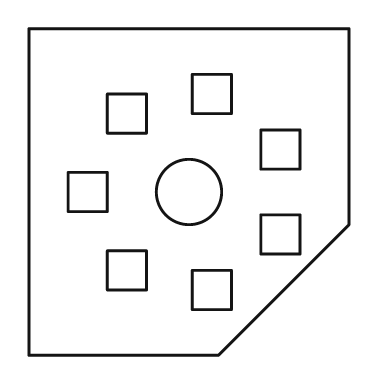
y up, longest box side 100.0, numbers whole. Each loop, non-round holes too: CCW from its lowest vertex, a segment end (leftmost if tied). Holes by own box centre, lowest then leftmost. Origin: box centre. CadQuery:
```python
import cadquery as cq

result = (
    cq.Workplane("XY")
    .moveTo(-49.0, -50.0)
    .lineTo(9.0, -50.0)
    .lineTo(49.0, -10.0)
    .lineTo(49.0, 50.0)
    .lineTo(-49.0, 50.0)
    .close()
    .moveTo(1.0, -36.0)
    .lineTo(13.0, -36.0)
    .lineTo(13.0, -24.0)
    .lineTo(1.0, -24.0)
    .close()
    .moveTo(-25.0, -30.0)
    .lineTo(-13.0, -30.0)
    .lineTo(-13.0, -18.0)
    .lineTo(-25.0, -18.0)
    .close()
    .moveTo(22.0, -19.0)
    .lineTo(34.0, -19.0)
    .lineTo(34.0, -7.0)
    .lineTo(22.0, -7.0)
    .close()
    .moveTo(-37.0, -6.0)
    .lineTo(-25.0, -6.0)
    .lineTo(-25.0, 6.0)
    .lineTo(-37.0, 6.0)
    .close()
    .moveTo(0.0, 0.0)
    .circle(10.0)
    .moveTo(22.0, 7.0)
    .lineTo(34.0, 7.0)
    .lineTo(34.0, 19.0)
    .lineTo(22.0, 19.0)
    .close()
    .moveTo(-25.0, 18.0)
    .lineTo(-13.0, 18.0)
    .lineTo(-13.0, 30.0)
    .lineTo(-25.0, 30.0)
    .close()
    .moveTo(1.0, 24.0)
    .lineTo(13.0, 24.0)
    .lineTo(13.0, 36.0)
    .lineTo(1.0, 36.0)
    .close()
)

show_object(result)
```